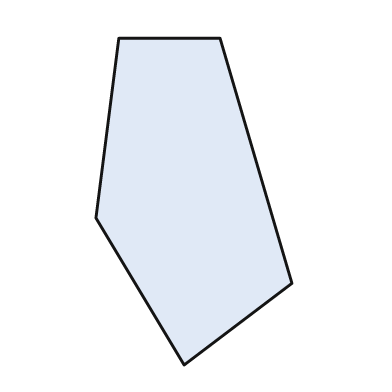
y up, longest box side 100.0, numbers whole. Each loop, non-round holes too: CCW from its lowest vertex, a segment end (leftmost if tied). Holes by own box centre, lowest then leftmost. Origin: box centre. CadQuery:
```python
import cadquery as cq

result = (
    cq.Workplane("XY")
    .moveTo(-3.0, -50.0)
    .lineTo(30.0, -25.0)
    .lineTo(8.0, 50.0)
    .lineTo(-23.0, 50.0)
    .lineTo(-30.0, -5.0)
    .close()
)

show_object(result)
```